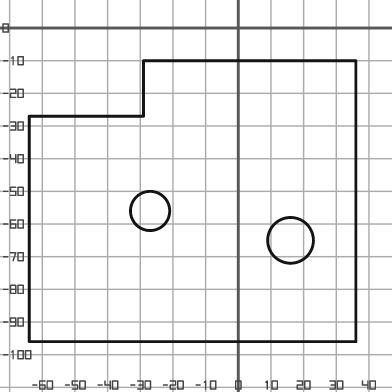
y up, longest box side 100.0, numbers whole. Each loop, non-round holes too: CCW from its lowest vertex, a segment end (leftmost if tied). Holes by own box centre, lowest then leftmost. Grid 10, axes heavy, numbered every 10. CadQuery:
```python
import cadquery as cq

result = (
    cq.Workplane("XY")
    .moveTo(-64.0, -96.0)
    .lineTo(36.0, -96.0)
    .lineTo(36.0, -10.0)
    .lineTo(-29.0, -10.0)
    .lineTo(-29.0, -27.0)
    .lineTo(-64.0, -27.0)
    .close()
    .moveTo(16.0, -65.0)
    .circle(7.0)
    .moveTo(-27.0, -56.0)
    .circle(6.0)
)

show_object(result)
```